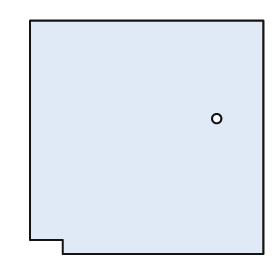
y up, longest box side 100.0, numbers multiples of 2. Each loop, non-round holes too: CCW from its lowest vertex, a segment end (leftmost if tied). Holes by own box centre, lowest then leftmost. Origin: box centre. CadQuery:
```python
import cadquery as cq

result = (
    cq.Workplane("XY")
    .moveTo(-36.0, -50.0)
    .lineTo(50.0, -50.0)
    .lineTo(50.0, 50.0)
    .lineTo(-50.0, 50.0)
    .lineTo(-50.0, -44.0)
    .lineTo(-36.0, -44.0)
    .close()
    .moveTo(30.0, 8.0)
    .circle(2.0)
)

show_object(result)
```